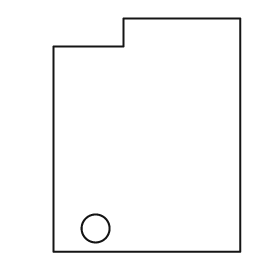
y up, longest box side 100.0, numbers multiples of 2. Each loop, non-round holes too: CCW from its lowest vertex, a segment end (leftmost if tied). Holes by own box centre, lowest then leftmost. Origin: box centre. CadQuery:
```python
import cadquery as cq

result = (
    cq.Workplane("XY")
    .moveTo(-40.0, -50.0)
    .lineTo(40.0, -50.0)
    .lineTo(40.0, 50.0)
    .lineTo(-10.0, 50.0)
    .lineTo(-10.0, 38.0)
    .lineTo(-40.0, 38.0)
    .close()
    .moveTo(-22.0, -40.0)
    .circle(6.0)
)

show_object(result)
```